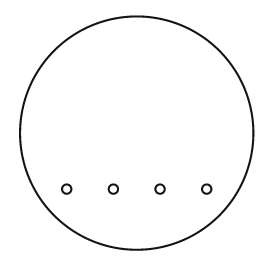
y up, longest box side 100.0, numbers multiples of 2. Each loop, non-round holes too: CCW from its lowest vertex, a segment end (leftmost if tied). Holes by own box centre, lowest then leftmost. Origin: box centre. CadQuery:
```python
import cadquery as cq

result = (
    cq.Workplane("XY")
    .moveTo(0.0, 0.0)
    .circle(50.0)
    .moveTo(-30.0, -24.0)
    .circle(2.0)
    .moveTo(-10.0, -24.0)
    .circle(2.0)
    .moveTo(10.0, -24.0)
    .circle(2.0)
    .moveTo(30.0, -24.0)
    .circle(2.0)
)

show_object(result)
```